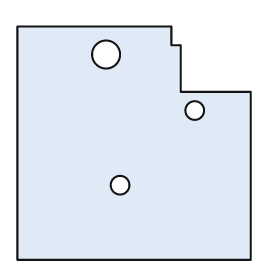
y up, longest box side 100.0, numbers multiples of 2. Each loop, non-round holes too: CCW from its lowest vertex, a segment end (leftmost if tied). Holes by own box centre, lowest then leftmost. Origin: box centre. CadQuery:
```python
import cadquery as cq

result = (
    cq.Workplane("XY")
    .moveTo(-50.0, -50.0)
    .lineTo(50.0, -50.0)
    .lineTo(50.0, 22.0)
    .lineTo(20.0, 22.0)
    .lineTo(20.0, 42.0)
    .lineTo(16.0, 42.0)
    .lineTo(16.0, 50.0)
    .lineTo(-50.0, 50.0)
    .close()
    .moveTo(-6.0, -18.0)
    .circle(4.0)
    .moveTo(26.0, 14.0)
    .circle(4.0)
    .moveTo(-12.0, 38.0)
    .circle(6.0)
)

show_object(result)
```